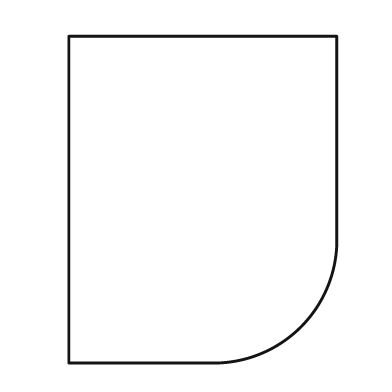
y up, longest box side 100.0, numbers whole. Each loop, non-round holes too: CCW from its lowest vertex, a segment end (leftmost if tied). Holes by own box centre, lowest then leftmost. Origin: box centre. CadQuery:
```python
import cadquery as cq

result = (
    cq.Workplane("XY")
    .moveTo(-41.0, -50.0)
    .lineTo(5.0, -50.0)
    .threePointArc((30.0, -39.0), (41.0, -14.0))
    .lineTo(41.0, 50.0)
    .lineTo(-41.0, 50.0)
    .close()
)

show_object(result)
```